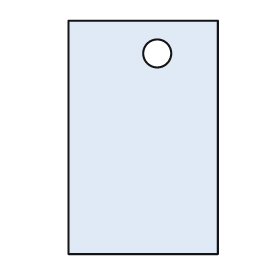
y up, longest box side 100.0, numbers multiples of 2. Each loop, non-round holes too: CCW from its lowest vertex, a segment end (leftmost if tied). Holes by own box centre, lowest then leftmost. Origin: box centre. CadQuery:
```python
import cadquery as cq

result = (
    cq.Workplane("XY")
    .moveTo(-32.0, -50.0)
    .lineTo(32.0, -50.0)
    .lineTo(32.0, 50.0)
    .lineTo(-32.0, 50.0)
    .close()
    .moveTo(6.0, 36.0)
    .circle(6.0)
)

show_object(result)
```